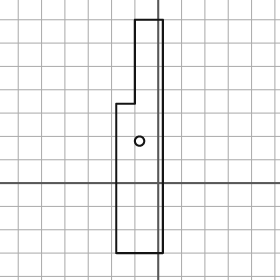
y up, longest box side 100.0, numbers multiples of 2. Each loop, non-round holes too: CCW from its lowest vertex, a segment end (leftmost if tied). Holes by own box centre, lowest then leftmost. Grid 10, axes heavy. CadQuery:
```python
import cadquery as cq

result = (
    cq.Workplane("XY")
    .moveTo(-18.0, -30.0)
    .lineTo(2.0, -30.0)
    .lineTo(2.0, 70.0)
    .lineTo(-10.0, 70.0)
    .lineTo(-10.0, 34.0)
    .lineTo(-18.0, 34.0)
    .close()
    .moveTo(-8.0, 18.0)
    .circle(2.0)
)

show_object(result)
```